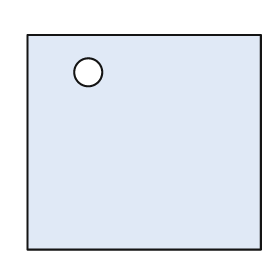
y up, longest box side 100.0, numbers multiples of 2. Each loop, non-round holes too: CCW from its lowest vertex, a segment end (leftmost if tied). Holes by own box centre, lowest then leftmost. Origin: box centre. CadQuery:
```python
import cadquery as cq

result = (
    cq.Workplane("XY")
    .moveTo(-50.0, -46.0)
    .lineTo(50.0, -46.0)
    .lineTo(50.0, 46.0)
    .lineTo(-50.0, 46.0)
    .close()
    .moveTo(-24.0, 30.0)
    .circle(6.0)
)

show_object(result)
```